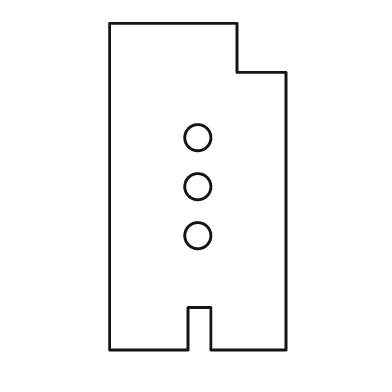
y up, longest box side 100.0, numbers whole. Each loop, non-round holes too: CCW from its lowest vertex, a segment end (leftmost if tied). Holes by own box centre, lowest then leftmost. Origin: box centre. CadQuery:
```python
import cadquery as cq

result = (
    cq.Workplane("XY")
    .moveTo(-27.0, -50.0)
    .lineTo(-3.0, -50.0)
    .lineTo(-3.0, -37.0)
    .lineTo(4.0, -37.0)
    .lineTo(4.0, -50.0)
    .lineTo(27.0, -50.0)
    .lineTo(27.0, 35.0)
    .lineTo(12.0, 35.0)
    .lineTo(12.0, 50.0)
    .lineTo(-27.0, 50.0)
    .close()
    .moveTo(0.0, -15.0)
    .circle(4.0)
    .moveTo(0.0, 0.0)
    .circle(4.0)
    .moveTo(0.0, 15.0)
    .circle(4.0)
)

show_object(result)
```